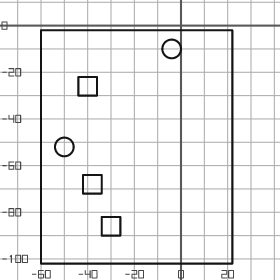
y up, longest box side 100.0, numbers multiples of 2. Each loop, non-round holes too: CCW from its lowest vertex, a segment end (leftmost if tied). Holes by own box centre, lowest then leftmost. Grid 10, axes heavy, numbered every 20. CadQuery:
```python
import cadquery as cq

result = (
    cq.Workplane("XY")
    .moveTo(-60.0, -102.0)
    .lineTo(22.0, -102.0)
    .lineTo(22.0, -2.0)
    .lineTo(-60.0, -2.0)
    .close()
    .moveTo(-34.0, -90.0)
    .lineTo(-26.0, -90.0)
    .lineTo(-26.0, -82.0)
    .lineTo(-34.0, -82.0)
    .close()
    .moveTo(-42.0, -72.0)
    .lineTo(-34.0, -72.0)
    .lineTo(-34.0, -64.0)
    .lineTo(-42.0, -64.0)
    .close()
    .moveTo(-50.0, -52.0)
    .circle(4.0)
    .moveTo(-44.0, -30.0)
    .lineTo(-36.0, -30.0)
    .lineTo(-36.0, -22.0)
    .lineTo(-44.0, -22.0)
    .close()
    .moveTo(-4.0, -10.0)
    .circle(4.0)
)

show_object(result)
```